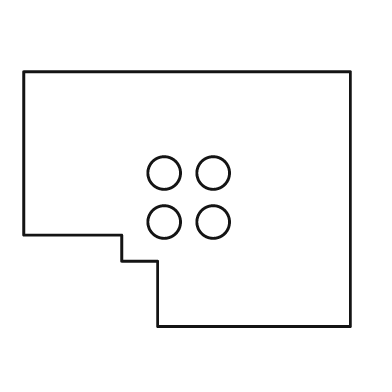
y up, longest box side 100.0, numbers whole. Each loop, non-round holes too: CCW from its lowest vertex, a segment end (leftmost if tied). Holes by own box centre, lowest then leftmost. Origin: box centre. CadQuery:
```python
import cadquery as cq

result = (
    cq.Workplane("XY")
    .moveTo(-9.0, -39.0)
    .lineTo(50.0, -39.0)
    .lineTo(50.0, 39.0)
    .lineTo(-50.0, 39.0)
    .lineTo(-50.0, -11.0)
    .lineTo(-20.0, -11.0)
    .lineTo(-20.0, -19.0)
    .lineTo(-9.0, -19.0)
    .close()
    .moveTo(-7.0, -7.0)
    .circle(5.0)
    .moveTo(8.0, -7.0)
    .circle(5.0)
    .moveTo(-7.0, 8.0)
    .circle(5.0)
    .moveTo(8.0, 8.0)
    .circle(5.0)
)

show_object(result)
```